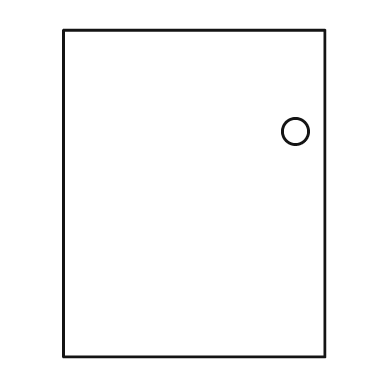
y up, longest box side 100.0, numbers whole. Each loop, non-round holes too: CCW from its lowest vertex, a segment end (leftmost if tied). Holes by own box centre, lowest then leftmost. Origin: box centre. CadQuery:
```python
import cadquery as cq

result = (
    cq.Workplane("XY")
    .moveTo(-40.0, -50.0)
    .lineTo(40.0, -50.0)
    .lineTo(40.0, 50.0)
    .lineTo(-40.0, 50.0)
    .close()
    .moveTo(31.0, 19.0)
    .circle(4.0)
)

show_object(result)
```